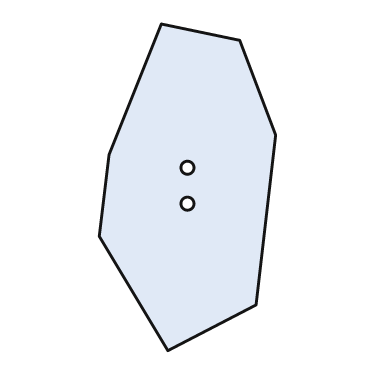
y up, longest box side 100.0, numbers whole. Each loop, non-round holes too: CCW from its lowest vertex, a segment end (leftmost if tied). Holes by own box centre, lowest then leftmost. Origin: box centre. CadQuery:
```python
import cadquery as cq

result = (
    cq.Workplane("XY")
    .moveTo(-6.0, -50.0)
    .lineTo(21.0, -36.0)
    .lineTo(27.0, 16.0)
    .lineTo(16.0, 45.0)
    .lineTo(-8.0, 50.0)
    .lineTo(-24.0, 10.0)
    .lineTo(-27.0, -15.0)
    .close()
    .moveTo(0.0, -5.0)
    .circle(2.0)
    .moveTo(0.0, 6.0)
    .circle(2.0)
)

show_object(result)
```